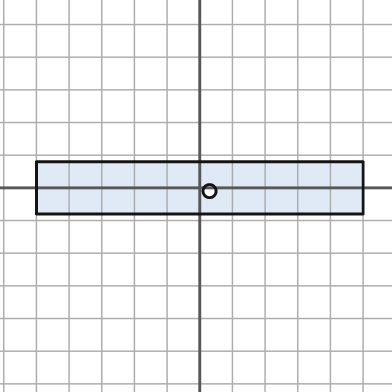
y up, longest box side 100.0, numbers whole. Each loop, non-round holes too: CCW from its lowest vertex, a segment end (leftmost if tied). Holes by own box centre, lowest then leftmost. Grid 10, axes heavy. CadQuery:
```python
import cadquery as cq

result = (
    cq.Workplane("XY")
    .moveTo(-50.0, -8.0)
    .lineTo(50.0, -8.0)
    .lineTo(50.0, 8.0)
    .lineTo(-50.0, 8.0)
    .close()
    .moveTo(3.0, -1.0)
    .circle(2.0)
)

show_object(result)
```